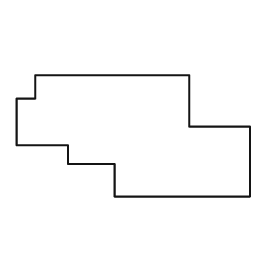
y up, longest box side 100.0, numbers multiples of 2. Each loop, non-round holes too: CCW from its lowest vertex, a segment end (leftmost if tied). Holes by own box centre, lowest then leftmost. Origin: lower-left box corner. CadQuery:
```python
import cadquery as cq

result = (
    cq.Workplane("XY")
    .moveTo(42.0, 0.0)
    .lineTo(100.0, 0.0)
    .lineTo(100.0, 30.0)
    .lineTo(74.0, 30.0)
    .lineTo(74.0, 52.0)
    .lineTo(8.0, 52.0)
    .lineTo(8.0, 42.0)
    .lineTo(0.0, 42.0)
    .lineTo(0.0, 22.0)
    .lineTo(22.0, 22.0)
    .lineTo(22.0, 14.0)
    .lineTo(42.0, 14.0)
    .close()
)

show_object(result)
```